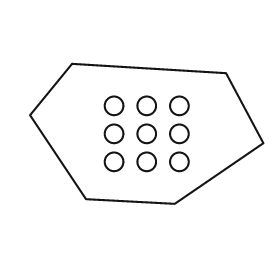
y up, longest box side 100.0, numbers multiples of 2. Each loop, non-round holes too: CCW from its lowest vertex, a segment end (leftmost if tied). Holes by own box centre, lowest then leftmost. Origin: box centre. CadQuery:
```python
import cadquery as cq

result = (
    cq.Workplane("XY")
    .moveTo(12.0, -30.0)
    .lineTo(50.0, -4.0)
    .lineTo(34.0, 26.0)
    .lineTo(-32.0, 30.0)
    .lineTo(-50.0, 8.0)
    .lineTo(-26.0, -28.0)
    .close()
    .moveTo(-14.0, -12.0)
    .circle(4.0)
    .moveTo(0.0, -12.0)
    .circle(4.0)
    .moveTo(14.0, -12.0)
    .circle(4.0)
    .moveTo(-14.0, 0.0)
    .circle(4.0)
    .moveTo(0.0, 0.0)
    .circle(4.0)
    .moveTo(14.0, 0.0)
    .circle(4.0)
    .moveTo(-14.0, 12.0)
    .circle(4.0)
    .moveTo(0.0, 12.0)
    .circle(4.0)
    .moveTo(14.0, 12.0)
    .circle(4.0)
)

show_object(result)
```